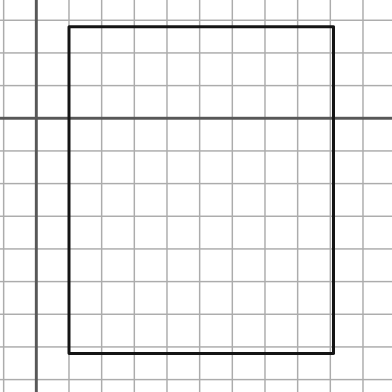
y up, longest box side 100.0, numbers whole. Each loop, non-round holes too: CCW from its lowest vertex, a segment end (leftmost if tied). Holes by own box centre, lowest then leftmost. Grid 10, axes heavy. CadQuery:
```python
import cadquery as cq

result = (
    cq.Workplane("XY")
    .moveTo(10.0, -72.0)
    .lineTo(91.0, -72.0)
    .lineTo(91.0, 28.0)
    .lineTo(10.0, 28.0)
    .close()
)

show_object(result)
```